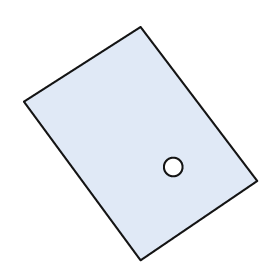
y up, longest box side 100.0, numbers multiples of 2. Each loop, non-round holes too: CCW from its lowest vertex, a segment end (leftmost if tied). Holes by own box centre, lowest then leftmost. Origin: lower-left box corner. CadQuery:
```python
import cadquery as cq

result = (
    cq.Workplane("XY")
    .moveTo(50.0, 0.0)
    .lineTo(100.0, 34.0)
    .lineTo(50.0, 100.0)
    .lineTo(0.0, 68.0)
    .close()
    .moveTo(64.0, 40.0)
    .circle(4.0)
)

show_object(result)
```